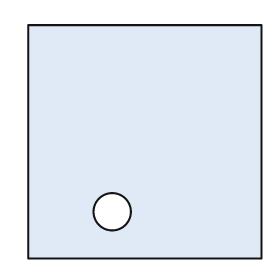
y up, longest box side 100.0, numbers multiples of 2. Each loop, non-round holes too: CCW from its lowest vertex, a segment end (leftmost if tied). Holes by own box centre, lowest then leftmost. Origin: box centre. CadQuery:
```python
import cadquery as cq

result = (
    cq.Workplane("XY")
    .moveTo(-50.0, -50.0)
    .lineTo(50.0, -50.0)
    .lineTo(50.0, 50.0)
    .lineTo(-50.0, 50.0)
    .close()
    .moveTo(-14.0, -30.0)
    .circle(8.0)
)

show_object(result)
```